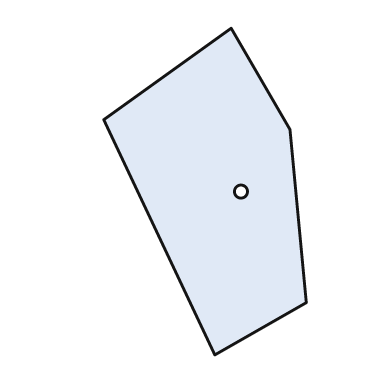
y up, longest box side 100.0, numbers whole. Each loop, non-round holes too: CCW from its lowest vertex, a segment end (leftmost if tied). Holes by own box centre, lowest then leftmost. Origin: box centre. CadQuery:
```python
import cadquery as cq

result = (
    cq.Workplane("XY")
    .moveTo(3.0, -50.0)
    .lineTo(31.0, -34.0)
    .lineTo(26.0, 19.0)
    .lineTo(8.0, 50.0)
    .lineTo(-31.0, 22.0)
    .close()
    .moveTo(11.0, 0.0)
    .circle(2.0)
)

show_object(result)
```